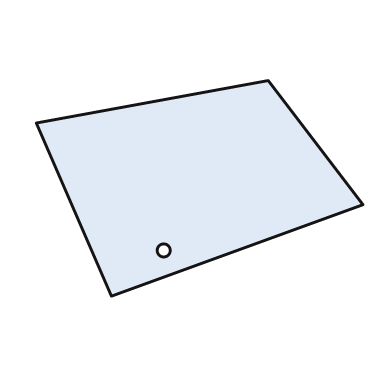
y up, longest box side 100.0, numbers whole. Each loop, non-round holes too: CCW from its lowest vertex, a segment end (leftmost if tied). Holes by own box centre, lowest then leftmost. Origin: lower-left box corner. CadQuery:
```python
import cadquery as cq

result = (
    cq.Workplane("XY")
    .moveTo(23.0, 0.0)
    .lineTo(100.0, 28.0)
    .lineTo(71.0, 66.0)
    .lineTo(0.0, 53.0)
    .close()
    .moveTo(39.0, 14.0)
    .circle(2.0)
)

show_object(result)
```